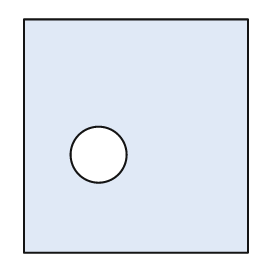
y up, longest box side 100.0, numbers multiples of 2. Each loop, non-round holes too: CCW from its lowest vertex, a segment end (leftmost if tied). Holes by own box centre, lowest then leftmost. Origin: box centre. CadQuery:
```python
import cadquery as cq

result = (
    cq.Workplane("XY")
    .moveTo(-48.0, -50.0)
    .lineTo(48.0, -50.0)
    .lineTo(48.0, 50.0)
    .lineTo(-48.0, 50.0)
    .close()
    .moveTo(-16.0, -8.0)
    .circle(12.0)
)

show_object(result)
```